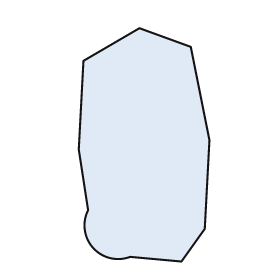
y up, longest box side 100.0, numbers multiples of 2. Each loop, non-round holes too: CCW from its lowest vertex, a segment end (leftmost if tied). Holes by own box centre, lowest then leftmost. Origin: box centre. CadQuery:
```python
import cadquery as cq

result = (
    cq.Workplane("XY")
    .moveTo(16.0, -50.0)
    .lineTo(26.0, -36.0)
    .lineTo(28.0, 2.0)
    .lineTo(20.0, 42.0)
    .lineTo(-2.0, 50.0)
    .lineTo(-26.0, 36.0)
    .lineTo(-28.0, -2.0)
    .lineTo(-24.0, -28.0)
    .threePointArc((-22.0, -44.0), (-6.0, -48.0))
    .close()
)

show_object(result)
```